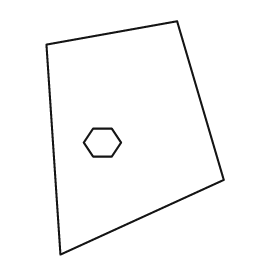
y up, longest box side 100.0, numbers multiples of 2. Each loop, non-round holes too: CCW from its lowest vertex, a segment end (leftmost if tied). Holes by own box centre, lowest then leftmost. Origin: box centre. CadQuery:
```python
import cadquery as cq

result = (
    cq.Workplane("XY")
    .moveTo(-32.0, -50.0)
    .lineTo(38.0, -18.0)
    .lineTo(18.0, 50.0)
    .lineTo(-38.0, 40.0)
    .close()
    .moveTo(-18.0, -8.0)
    .lineTo(-10.0, -8.0)
    .lineTo(-6.0, -2.0)
    .lineTo(-10.0, 4.0)
    .lineTo(-18.0, 4.0)
    .lineTo(-22.0, -2.0)
    .close()
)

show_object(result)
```